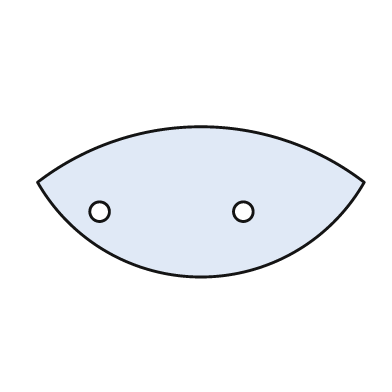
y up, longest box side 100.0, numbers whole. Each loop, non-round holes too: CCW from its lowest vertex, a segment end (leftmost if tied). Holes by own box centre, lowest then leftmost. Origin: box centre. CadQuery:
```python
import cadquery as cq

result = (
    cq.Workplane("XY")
    .moveTo(-50.0, 6.0)
    .threePointArc((0.0, -23.0), (50.0, 6.0))
    .threePointArc((0.0, 23.0), (-50.0, 6.0))
    .close()
    .moveTo(-31.0, -3.0)
    .circle(3.0)
    .moveTo(13.0, -3.0)
    .circle(3.0)
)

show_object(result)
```